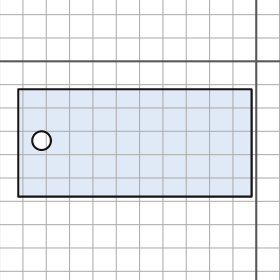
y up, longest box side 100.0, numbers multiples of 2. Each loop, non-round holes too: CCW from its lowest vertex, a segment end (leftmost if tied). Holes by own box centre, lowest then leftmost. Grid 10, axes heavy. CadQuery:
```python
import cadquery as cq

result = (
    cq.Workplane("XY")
    .moveTo(-102.0, -58.0)
    .lineTo(-2.0, -58.0)
    .lineTo(-2.0, -12.0)
    .lineTo(-102.0, -12.0)
    .close()
    .moveTo(-92.0, -34.0)
    .circle(4.0)
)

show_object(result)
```